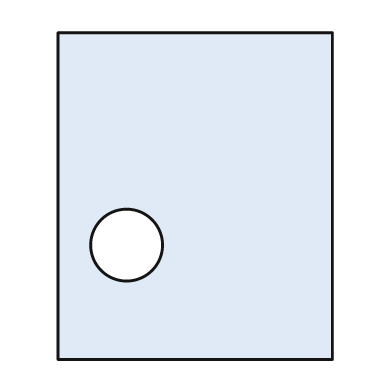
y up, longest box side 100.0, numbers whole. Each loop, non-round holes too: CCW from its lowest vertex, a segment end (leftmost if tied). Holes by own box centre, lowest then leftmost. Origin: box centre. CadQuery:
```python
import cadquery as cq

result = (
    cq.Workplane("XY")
    .moveTo(-42.0, -50.0)
    .lineTo(42.0, -50.0)
    .lineTo(42.0, 50.0)
    .lineTo(-42.0, 50.0)
    .close()
    .moveTo(-21.0, -15.0)
    .circle(11.0)
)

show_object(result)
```